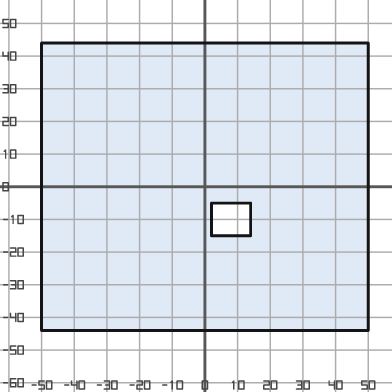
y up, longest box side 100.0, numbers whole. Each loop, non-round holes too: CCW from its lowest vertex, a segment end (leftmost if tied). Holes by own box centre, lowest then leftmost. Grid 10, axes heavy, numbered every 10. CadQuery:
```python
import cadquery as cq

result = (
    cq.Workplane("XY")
    .moveTo(-50.0, -44.0)
    .lineTo(50.0, -44.0)
    .lineTo(50.0, 44.0)
    .lineTo(-50.0, 44.0)
    .close()
    .moveTo(2.0, -15.0)
    .lineTo(14.0, -15.0)
    .lineTo(14.0, -5.0)
    .lineTo(2.0, -5.0)
    .close()
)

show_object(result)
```